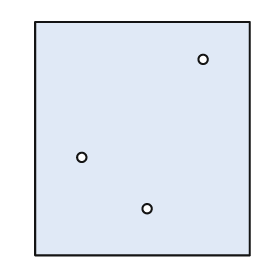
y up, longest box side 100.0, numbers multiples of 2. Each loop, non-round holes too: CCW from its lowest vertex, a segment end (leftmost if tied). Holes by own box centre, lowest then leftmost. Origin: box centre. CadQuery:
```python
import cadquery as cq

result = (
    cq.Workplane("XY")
    .moveTo(-46.0, -50.0)
    .lineTo(46.0, -50.0)
    .lineTo(46.0, 50.0)
    .lineTo(-46.0, 50.0)
    .close()
    .moveTo(2.0, -30.0)
    .circle(2.0)
    .moveTo(-26.0, -8.0)
    .circle(2.0)
    .moveTo(26.0, 34.0)
    .circle(2.0)
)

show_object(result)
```